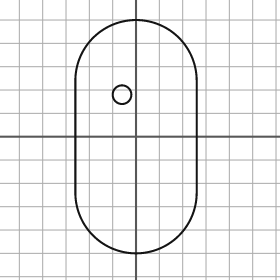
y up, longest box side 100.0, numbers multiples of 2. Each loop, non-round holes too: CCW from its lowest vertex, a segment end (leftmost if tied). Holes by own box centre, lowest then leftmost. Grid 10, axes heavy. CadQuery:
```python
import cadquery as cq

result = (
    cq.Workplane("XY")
    .moveTo(-26.0, -24.0)
    .threePointArc((0.0, -50.0), (26.0, -24.0))
    .lineTo(26.0, 24.0)
    .threePointArc((0.0, 50.0), (-26.0, 24.0))
    .close()
    .moveTo(-6.0, 18.0)
    .circle(4.0)
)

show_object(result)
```